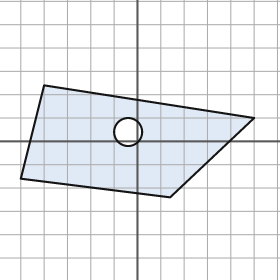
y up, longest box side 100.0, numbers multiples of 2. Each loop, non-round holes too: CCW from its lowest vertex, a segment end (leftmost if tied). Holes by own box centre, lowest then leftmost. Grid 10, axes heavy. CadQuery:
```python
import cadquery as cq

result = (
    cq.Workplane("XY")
    .moveTo(14.0, -24.0)
    .lineTo(50.0, 10.0)
    .lineTo(-40.0, 24.0)
    .lineTo(-50.0, -16.0)
    .close()
    .moveTo(-4.0, 4.0)
    .circle(6.0)
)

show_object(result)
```